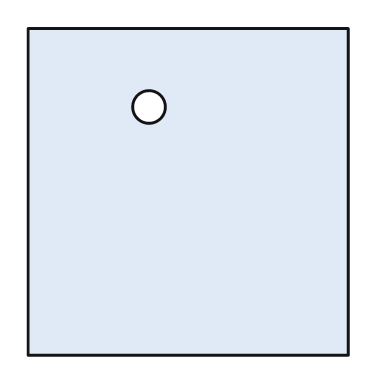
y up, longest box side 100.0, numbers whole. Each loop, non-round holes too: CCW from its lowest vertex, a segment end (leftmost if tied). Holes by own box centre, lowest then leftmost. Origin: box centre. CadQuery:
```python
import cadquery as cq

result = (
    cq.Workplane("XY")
    .moveTo(-49.0, -50.0)
    .lineTo(49.0, -50.0)
    .lineTo(49.0, 50.0)
    .lineTo(-49.0, 50.0)
    .close()
    .moveTo(-12.0, 26.0)
    .circle(5.0)
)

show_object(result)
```